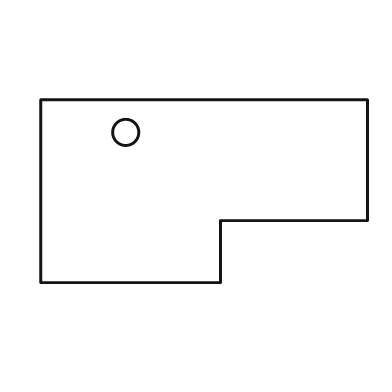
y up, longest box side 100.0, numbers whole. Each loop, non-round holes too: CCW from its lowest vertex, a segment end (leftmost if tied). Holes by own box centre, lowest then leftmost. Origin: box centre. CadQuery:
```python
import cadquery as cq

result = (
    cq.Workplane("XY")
    .moveTo(-50.0, -28.0)
    .lineTo(5.0, -28.0)
    .lineTo(5.0, -9.0)
    .lineTo(50.0, -9.0)
    .lineTo(50.0, 28.0)
    .lineTo(-50.0, 28.0)
    .close()
    .moveTo(-24.0, 18.0)
    .circle(4.0)
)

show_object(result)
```